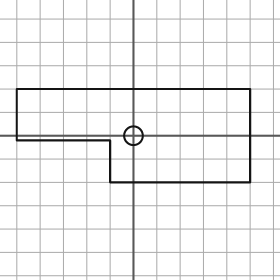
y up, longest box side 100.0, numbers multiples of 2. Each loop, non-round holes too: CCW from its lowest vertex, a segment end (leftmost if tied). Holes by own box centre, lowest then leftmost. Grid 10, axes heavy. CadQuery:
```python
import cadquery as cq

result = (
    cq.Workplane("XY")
    .moveTo(-10.0, -20.0)
    .lineTo(50.0, -20.0)
    .lineTo(50.0, 20.0)
    .lineTo(-50.0, 20.0)
    .lineTo(-50.0, -2.0)
    .lineTo(-10.0, -2.0)
    .close()
    .moveTo(0.0, 0.0)
    .circle(4.0)
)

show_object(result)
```